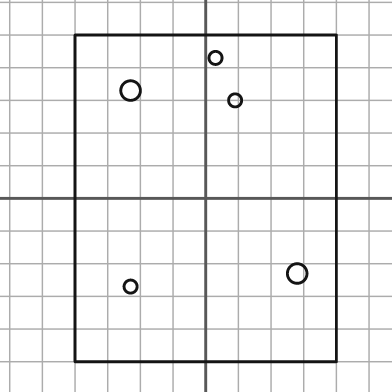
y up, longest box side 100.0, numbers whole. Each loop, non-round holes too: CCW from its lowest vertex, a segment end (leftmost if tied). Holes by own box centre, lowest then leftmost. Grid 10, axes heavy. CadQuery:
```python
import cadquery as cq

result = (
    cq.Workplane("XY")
    .moveTo(-40.0, -50.0)
    .lineTo(40.0, -50.0)
    .lineTo(40.0, 50.0)
    .lineTo(-40.0, 50.0)
    .close()
    .moveTo(-23.0, -27.0)
    .circle(2.0)
    .moveTo(28.0, -23.0)
    .circle(3.0)
    .moveTo(9.0, 30.0)
    .circle(2.0)
    .moveTo(-23.0, 33.0)
    .circle(3.0)
    .moveTo(3.0, 43.0)
    .circle(2.0)
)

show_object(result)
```